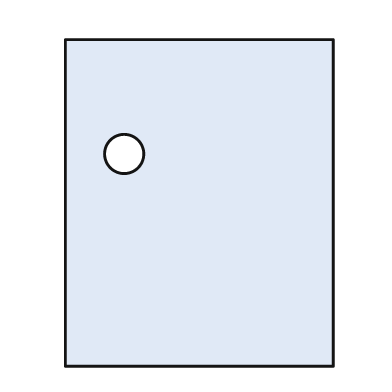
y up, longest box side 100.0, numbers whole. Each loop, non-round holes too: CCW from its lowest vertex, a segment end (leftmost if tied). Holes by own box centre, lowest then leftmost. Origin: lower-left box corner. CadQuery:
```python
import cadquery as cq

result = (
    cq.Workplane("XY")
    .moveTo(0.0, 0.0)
    .lineTo(82.0, 0.0)
    .lineTo(82.0, 100.0)
    .lineTo(0.0, 100.0)
    .close()
    .moveTo(18.0, 65.0)
    .circle(6.0)
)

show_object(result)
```